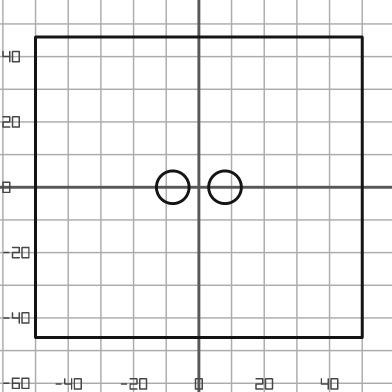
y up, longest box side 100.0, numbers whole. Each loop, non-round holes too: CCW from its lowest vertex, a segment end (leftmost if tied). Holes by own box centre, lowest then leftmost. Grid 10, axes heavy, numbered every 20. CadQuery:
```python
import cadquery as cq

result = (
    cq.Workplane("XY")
    .moveTo(-50.0, -46.0)
    .lineTo(50.0, -46.0)
    .lineTo(50.0, 46.0)
    .lineTo(-50.0, 46.0)
    .close()
    .moveTo(-8.0, 0.0)
    .circle(5.0)
    .moveTo(8.0, 0.0)
    .circle(5.0)
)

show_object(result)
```